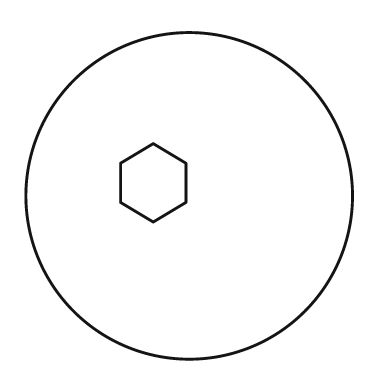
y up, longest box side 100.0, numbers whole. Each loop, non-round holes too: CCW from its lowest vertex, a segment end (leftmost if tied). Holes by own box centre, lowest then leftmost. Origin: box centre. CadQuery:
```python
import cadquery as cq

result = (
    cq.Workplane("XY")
    .moveTo(0.0, 0.0)
    .circle(50.0)
    .moveTo(-11.0, -8.0)
    .lineTo(-1.0, -2.0)
    .lineTo(-1.0, 10.0)
    .lineTo(-11.0, 16.0)
    .lineTo(-21.0, 10.0)
    .lineTo(-21.0, -2.0)
    .close()
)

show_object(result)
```